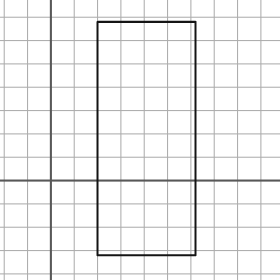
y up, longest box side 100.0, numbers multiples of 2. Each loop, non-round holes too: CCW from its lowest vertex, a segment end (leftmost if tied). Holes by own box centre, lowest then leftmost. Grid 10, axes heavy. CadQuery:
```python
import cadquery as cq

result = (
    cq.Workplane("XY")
    .moveTo(20.0, -32.0)
    .lineTo(62.0, -32.0)
    .lineTo(62.0, 68.0)
    .lineTo(20.0, 68.0)
    .close()
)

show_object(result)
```